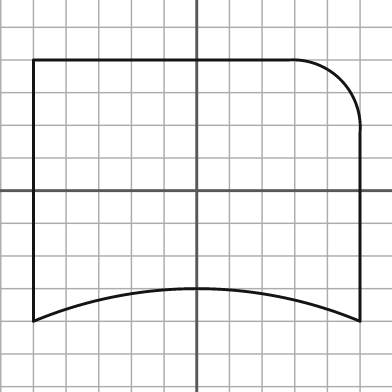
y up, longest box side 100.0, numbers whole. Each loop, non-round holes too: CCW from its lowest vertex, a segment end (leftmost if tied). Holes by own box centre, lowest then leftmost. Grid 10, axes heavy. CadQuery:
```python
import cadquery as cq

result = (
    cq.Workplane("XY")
    .moveTo(-50.0, -40.0)
    .threePointArc((0.0, -30.0), (50.0, -40.0))
    .lineTo(50.0, 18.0)
    .threePointArc((44.0, 34.0), (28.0, 40.0))
    .lineTo(-50.0, 40.0)
    .close()
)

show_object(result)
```